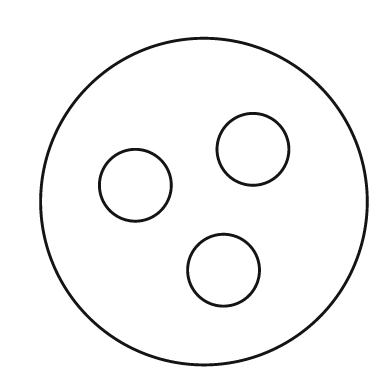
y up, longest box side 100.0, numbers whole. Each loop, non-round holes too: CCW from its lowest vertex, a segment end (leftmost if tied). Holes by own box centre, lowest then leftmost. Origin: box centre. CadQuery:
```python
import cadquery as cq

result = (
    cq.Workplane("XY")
    .moveTo(0.0, 0.0)
    .circle(50.0)
    .moveTo(6.0, -21.0)
    .circle(11.0)
    .moveTo(-21.0, 5.0)
    .circle(11.0)
    .moveTo(15.0, 16.0)
    .circle(11.0)
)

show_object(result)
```